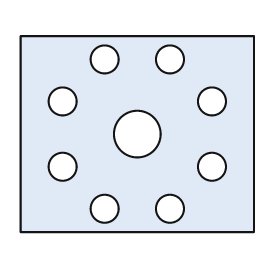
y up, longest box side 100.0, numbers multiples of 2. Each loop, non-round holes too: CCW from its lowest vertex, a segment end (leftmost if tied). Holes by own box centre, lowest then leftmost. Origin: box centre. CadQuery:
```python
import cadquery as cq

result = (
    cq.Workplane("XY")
    .moveTo(-50.0, -42.0)
    .lineTo(50.0, -42.0)
    .lineTo(50.0, 42.0)
    .lineTo(-50.0, 42.0)
    .close()
    .moveTo(-14.0, -32.0)
    .circle(6.0)
    .moveTo(14.0, -32.0)
    .circle(6.0)
    .moveTo(-32.0, -14.0)
    .circle(6.0)
    .moveTo(32.0, -14.0)
    .circle(6.0)
    .moveTo(0.0, 0.0)
    .circle(10.0)
    .moveTo(-32.0, 14.0)
    .circle(6.0)
    .moveTo(32.0, 14.0)
    .circle(6.0)
    .moveTo(-14.0, 32.0)
    .circle(6.0)
    .moveTo(14.0, 32.0)
    .circle(6.0)
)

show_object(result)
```